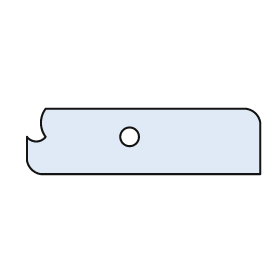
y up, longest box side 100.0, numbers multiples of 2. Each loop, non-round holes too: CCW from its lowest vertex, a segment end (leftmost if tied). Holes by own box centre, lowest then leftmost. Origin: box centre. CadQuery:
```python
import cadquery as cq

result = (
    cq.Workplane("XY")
    .moveTo(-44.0, -14.0)
    .lineTo(50.0, -14.0)
    .lineTo(50.0, 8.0)
    .threePointArc((48.0, 12.0), (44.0, 14.0))
    .lineTo(-42.0, 14.0)
    .threePointArc((-44.0, 8.0), (-42.0, 2.0))
    .threePointArc((-46.0, 0.0), (-50.0, 2.0))
    .lineTo(-50.0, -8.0)
    .threePointArc((-48.0, -12.0), (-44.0, -14.0))
    .close()
    .moveTo(-6.0, 2.0)
    .circle(4.0)
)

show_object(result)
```